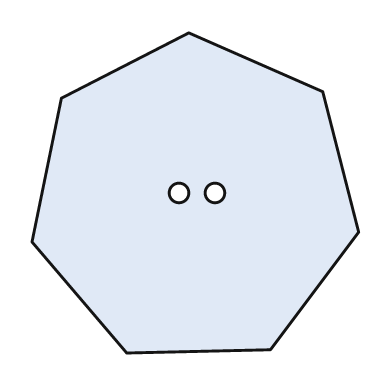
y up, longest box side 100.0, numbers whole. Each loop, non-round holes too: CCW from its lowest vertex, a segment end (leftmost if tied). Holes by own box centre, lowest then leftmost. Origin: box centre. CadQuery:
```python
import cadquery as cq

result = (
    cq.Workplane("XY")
    .moveTo(-21.0, -49.0)
    .lineTo(23.0, -48.0)
    .lineTo(50.0, -12.0)
    .lineTo(39.0, 31.0)
    .lineTo(-2.0, 49.0)
    .lineTo(-41.0, 29.0)
    .lineTo(-50.0, -15.0)
    .close()
    .moveTo(-5.0, 0.0)
    .circle(3.0)
    .moveTo(6.0, 0.0)
    .circle(3.0)
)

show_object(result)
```